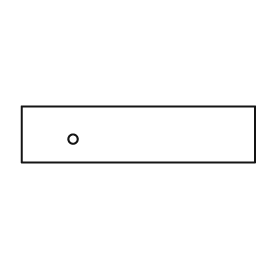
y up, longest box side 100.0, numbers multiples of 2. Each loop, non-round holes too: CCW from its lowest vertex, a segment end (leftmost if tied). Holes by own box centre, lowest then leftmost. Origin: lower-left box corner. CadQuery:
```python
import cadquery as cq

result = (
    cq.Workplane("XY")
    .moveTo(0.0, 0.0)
    .lineTo(100.0, 0.0)
    .lineTo(100.0, 24.0)
    .lineTo(0.0, 24.0)
    .close()
    .moveTo(22.0, 10.0)
    .circle(2.0)
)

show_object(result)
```